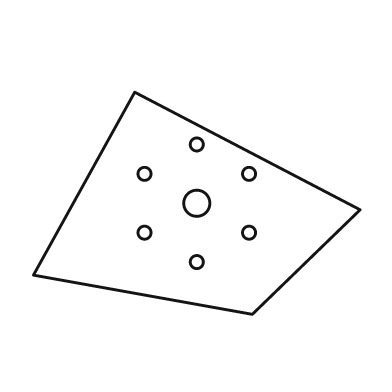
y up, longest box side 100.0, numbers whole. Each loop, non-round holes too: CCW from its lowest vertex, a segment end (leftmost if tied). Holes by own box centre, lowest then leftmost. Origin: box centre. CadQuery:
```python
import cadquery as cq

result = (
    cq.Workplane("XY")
    .moveTo(17.0, -34.0)
    .lineTo(50.0, -2.0)
    .lineTo(-19.0, 34.0)
    .lineTo(-50.0, -22.0)
    .close()
    .moveTo(0.0, -18.0)
    .circle(2.0)
    .moveTo(-16.0, -9.0)
    .circle(2.0)
    .moveTo(16.0, -9.0)
    .circle(2.0)
    .moveTo(0.0, 0.0)
    .circle(4.0)
    .moveTo(-16.0, 9.0)
    .circle(2.0)
    .moveTo(16.0, 9.0)
    .circle(2.0)
    .moveTo(0.0, 18.0)
    .circle(2.0)
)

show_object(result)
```